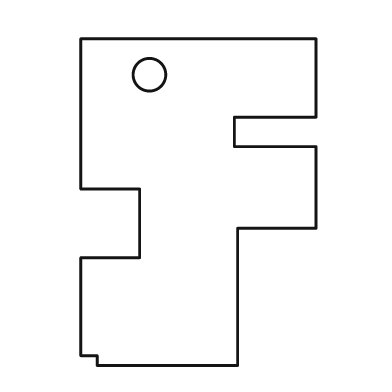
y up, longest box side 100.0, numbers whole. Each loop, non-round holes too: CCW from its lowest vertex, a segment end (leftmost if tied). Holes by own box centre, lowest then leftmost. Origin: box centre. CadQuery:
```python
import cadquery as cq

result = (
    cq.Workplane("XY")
    .moveTo(-31.0, -50.0)
    .lineTo(12.0, -50.0)
    .lineTo(12.0, -8.0)
    .lineTo(36.0, -8.0)
    .lineTo(36.0, 17.0)
    .lineTo(11.0, 17.0)
    .lineTo(11.0, 26.0)
    .lineTo(36.0, 26.0)
    .lineTo(36.0, 50.0)
    .lineTo(-36.0, 50.0)
    .lineTo(-36.0, 4.0)
    .lineTo(-18.0, 4.0)
    .lineTo(-18.0, -17.0)
    .lineTo(-36.0, -17.0)
    .lineTo(-36.0, -47.0)
    .lineTo(-31.0, -47.0)
    .close()
    .moveTo(-15.0, 39.0)
    .circle(5.0)
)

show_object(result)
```